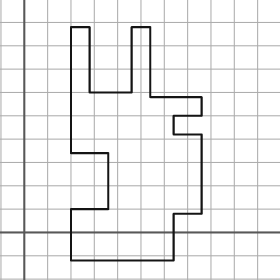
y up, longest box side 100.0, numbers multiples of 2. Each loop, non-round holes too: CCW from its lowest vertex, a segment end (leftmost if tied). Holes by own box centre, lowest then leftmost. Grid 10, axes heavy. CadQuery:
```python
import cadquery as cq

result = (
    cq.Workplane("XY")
    .moveTo(20.0, -12.0)
    .lineTo(64.0, -12.0)
    .lineTo(64.0, 8.0)
    .lineTo(76.0, 8.0)
    .lineTo(76.0, 42.0)
    .lineTo(64.0, 42.0)
    .lineTo(64.0, 50.0)
    .lineTo(76.0, 50.0)
    .lineTo(76.0, 58.0)
    .lineTo(54.0, 58.0)
    .lineTo(54.0, 88.0)
    .lineTo(46.0, 88.0)
    .lineTo(46.0, 60.0)
    .lineTo(28.0, 60.0)
    .lineTo(28.0, 88.0)
    .lineTo(20.0, 88.0)
    .lineTo(20.0, 34.0)
    .lineTo(36.0, 34.0)
    .lineTo(36.0, 10.0)
    .lineTo(20.0, 10.0)
    .close()
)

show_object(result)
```